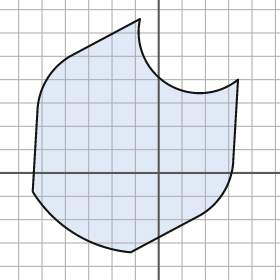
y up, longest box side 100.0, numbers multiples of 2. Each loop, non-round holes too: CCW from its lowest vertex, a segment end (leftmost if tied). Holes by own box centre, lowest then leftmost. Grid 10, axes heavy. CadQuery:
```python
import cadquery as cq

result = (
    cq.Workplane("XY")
    .moveTo(-12.0, -34.0)
    .lineTo(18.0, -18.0)
    .threePointArc((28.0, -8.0), (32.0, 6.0))
    .lineTo(34.0, 40.0)
    .threePointArc((4.0, 38.0), (-8.0, 66.0))
    .lineTo(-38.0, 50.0)
    .threePointArc((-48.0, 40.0), (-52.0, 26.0))
    .lineTo(-54.0, -8.0)
    .threePointArc((-36.0, -26.0), (-12.0, -34.0))
    .close()
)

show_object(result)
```